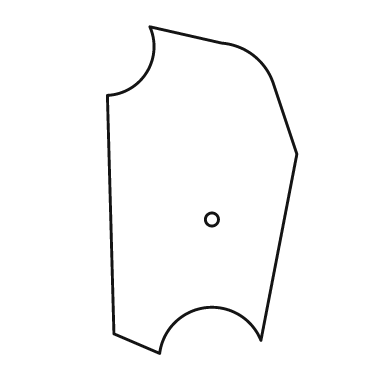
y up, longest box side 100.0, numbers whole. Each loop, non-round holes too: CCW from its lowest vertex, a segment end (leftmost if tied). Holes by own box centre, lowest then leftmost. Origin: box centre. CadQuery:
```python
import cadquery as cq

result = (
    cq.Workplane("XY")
    .moveTo(-13.0, -50.0)
    .threePointArc((1.0, -36.0), (18.0, -46.0))
    .lineTo(29.0, 11.0)
    .lineTo(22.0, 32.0)
    .threePointArc((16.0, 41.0), (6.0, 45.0))
    .lineTo(-16.0, 50.0)
    .threePointArc((-17.0, 36.0), (-29.0, 29.0))
    .lineTo(-27.0, -44.0)
    .close()
    .moveTo(3.0, -9.0)
    .circle(2.0)
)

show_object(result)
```